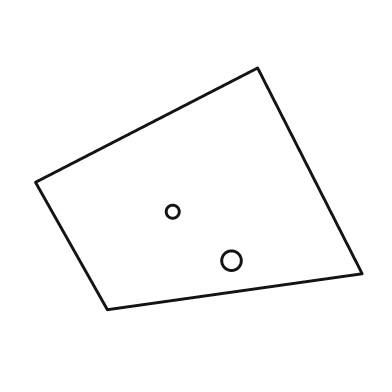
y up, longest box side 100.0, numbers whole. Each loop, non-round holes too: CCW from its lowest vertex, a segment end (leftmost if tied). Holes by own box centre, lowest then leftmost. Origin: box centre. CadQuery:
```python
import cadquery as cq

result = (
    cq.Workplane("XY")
    .moveTo(-28.0, -37.0)
    .lineTo(50.0, -26.0)
    .lineTo(18.0, 37.0)
    .lineTo(-50.0, 2.0)
    .close()
    .moveTo(10.0, -22.0)
    .circle(3.0)
    .moveTo(-8.0, -7.0)
    .circle(2.0)
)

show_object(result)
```